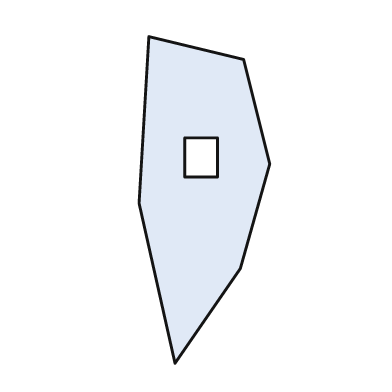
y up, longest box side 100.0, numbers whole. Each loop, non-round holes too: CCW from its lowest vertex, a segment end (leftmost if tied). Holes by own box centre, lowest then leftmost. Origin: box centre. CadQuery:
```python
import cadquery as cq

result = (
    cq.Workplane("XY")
    .moveTo(-9.0, -50.0)
    .lineTo(11.0, -21.0)
    .lineTo(20.0, 11.0)
    .lineTo(12.0, 43.0)
    .lineTo(-17.0, 50.0)
    .lineTo(-20.0, -1.0)
    .close()
    .moveTo(-6.0, 7.0)
    .lineTo(4.0, 7.0)
    .lineTo(4.0, 19.0)
    .lineTo(-6.0, 19.0)
    .close()
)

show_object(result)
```